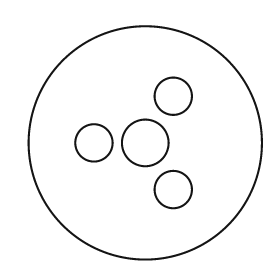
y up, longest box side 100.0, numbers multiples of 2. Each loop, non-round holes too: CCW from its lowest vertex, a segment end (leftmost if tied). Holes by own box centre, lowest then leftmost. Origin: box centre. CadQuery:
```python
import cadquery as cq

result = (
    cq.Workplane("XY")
    .moveTo(0.0, 0.0)
    .circle(50.0)
    .moveTo(12.0, -20.0)
    .circle(8.0)
    .moveTo(-22.0, 0.0)
    .circle(8.0)
    .moveTo(0.0, 0.0)
    .circle(10.0)
    .moveTo(12.0, 20.0)
    .circle(8.0)
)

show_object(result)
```